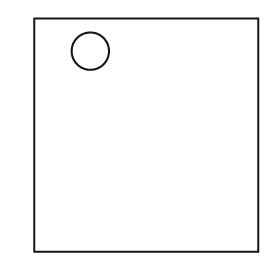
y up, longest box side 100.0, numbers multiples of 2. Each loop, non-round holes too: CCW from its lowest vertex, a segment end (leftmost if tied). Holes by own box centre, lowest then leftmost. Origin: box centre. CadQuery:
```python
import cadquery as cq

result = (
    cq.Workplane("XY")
    .moveTo(-48.0, -50.0)
    .lineTo(48.0, -50.0)
    .lineTo(48.0, 50.0)
    .lineTo(-48.0, 50.0)
    .close()
    .moveTo(-24.0, 36.0)
    .circle(8.0)
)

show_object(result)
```